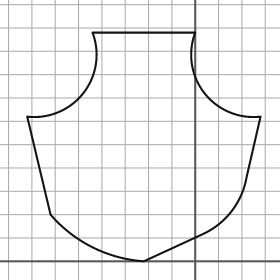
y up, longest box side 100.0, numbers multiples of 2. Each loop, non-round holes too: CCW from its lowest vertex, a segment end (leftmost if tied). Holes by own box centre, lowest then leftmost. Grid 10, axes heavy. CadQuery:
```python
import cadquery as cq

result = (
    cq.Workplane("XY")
    .moveTo(-22.0, 0.0)
    .lineTo(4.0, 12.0)
    .threePointArc((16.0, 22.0), (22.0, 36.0))
    .lineTo(28.0, 62.0)
    .threePointArc((4.0, 72.0), (0.0, 98.0))
    .lineTo(-44.0, 98.0)
    .threePointArc((-48.0, 72.0), (-72.0, 62.0))
    .lineTo(-62.0, 20.0)
    .threePointArc((-44.0, 6.0), (-22.0, 0.0))
    .close()
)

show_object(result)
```